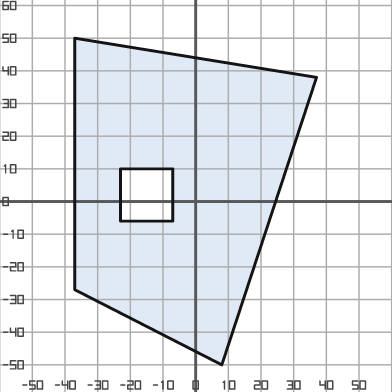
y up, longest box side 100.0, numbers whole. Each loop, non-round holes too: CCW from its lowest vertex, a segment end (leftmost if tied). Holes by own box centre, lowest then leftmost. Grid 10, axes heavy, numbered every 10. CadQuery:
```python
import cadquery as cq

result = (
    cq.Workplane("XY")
    .moveTo(8.0, -50.0)
    .lineTo(37.0, 38.0)
    .lineTo(-37.0, 50.0)
    .lineTo(-37.0, -27.0)
    .close()
    .moveTo(-23.0, -6.0)
    .lineTo(-7.0, -6.0)
    .lineTo(-7.0, 10.0)
    .lineTo(-23.0, 10.0)
    .close()
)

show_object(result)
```